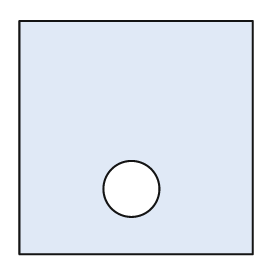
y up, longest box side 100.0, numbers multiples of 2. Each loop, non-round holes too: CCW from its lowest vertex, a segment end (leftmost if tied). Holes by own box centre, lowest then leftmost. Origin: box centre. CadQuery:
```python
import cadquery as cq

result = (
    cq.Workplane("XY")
    .moveTo(-50.0, -50.0)
    .lineTo(50.0, -50.0)
    .lineTo(50.0, 50.0)
    .lineTo(-50.0, 50.0)
    .close()
    .moveTo(-2.0, -22.0)
    .circle(12.0)
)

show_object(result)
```